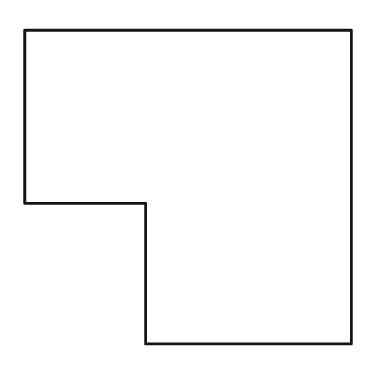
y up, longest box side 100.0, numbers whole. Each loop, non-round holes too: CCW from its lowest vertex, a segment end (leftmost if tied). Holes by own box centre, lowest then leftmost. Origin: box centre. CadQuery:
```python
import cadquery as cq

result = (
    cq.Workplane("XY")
    .moveTo(-13.0, -48.0)
    .lineTo(50.0, -48.0)
    .lineTo(50.0, 48.0)
    .lineTo(-50.0, 48.0)
    .lineTo(-50.0, -5.0)
    .lineTo(-13.0, -5.0)
    .close()
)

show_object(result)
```